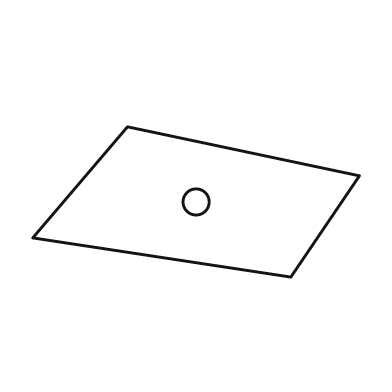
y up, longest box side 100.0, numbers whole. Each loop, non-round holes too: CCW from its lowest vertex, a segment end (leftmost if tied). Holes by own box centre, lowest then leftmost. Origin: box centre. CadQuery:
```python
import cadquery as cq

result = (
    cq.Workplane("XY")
    .moveTo(29.0, -23.0)
    .lineTo(50.0, 8.0)
    .lineTo(-21.0, 23.0)
    .lineTo(-50.0, -11.0)
    .close()
    .moveTo(0.0, 0.0)
    .circle(4.0)
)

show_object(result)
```